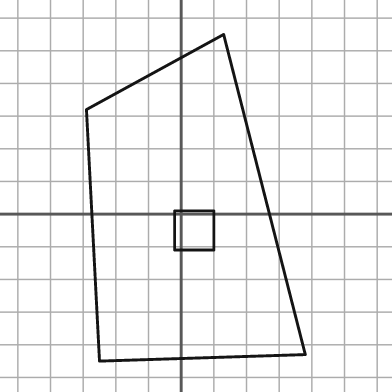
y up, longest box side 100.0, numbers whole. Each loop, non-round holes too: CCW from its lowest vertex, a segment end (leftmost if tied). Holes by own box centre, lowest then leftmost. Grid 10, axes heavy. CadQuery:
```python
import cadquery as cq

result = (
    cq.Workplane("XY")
    .moveTo(-25.0, -45.0)
    .lineTo(38.0, -43.0)
    .lineTo(13.0, 55.0)
    .lineTo(-29.0, 32.0)
    .close()
    .moveTo(-2.0, -11.0)
    .lineTo(10.0, -11.0)
    .lineTo(10.0, 1.0)
    .lineTo(-2.0, 1.0)
    .close()
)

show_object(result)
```